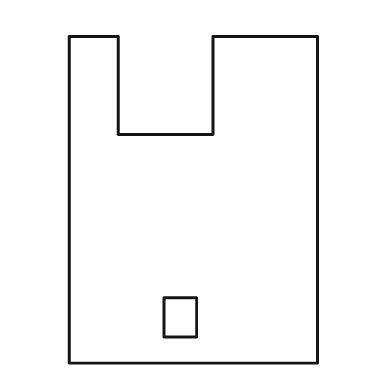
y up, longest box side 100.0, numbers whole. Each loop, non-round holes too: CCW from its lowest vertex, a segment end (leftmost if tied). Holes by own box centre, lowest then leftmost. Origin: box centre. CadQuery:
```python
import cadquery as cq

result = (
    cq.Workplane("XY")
    .moveTo(-38.0, -50.0)
    .lineTo(38.0, -50.0)
    .lineTo(38.0, 50.0)
    .lineTo(6.0, 50.0)
    .lineTo(6.0, 20.0)
    .lineTo(-23.0, 20.0)
    .lineTo(-23.0, 50.0)
    .lineTo(-38.0, 50.0)
    .close()
    .moveTo(-9.0, -42.0)
    .lineTo(1.0, -42.0)
    .lineTo(1.0, -30.0)
    .lineTo(-9.0, -30.0)
    .close()
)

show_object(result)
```